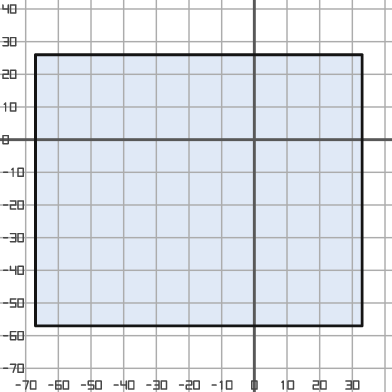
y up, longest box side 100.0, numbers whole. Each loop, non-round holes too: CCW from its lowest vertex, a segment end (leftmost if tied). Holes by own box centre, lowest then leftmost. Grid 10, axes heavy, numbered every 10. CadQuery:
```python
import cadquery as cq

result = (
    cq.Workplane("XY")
    .moveTo(-67.0, -57.0)
    .lineTo(33.0, -57.0)
    .lineTo(33.0, 26.0)
    .lineTo(-67.0, 26.0)
    .close()
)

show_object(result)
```